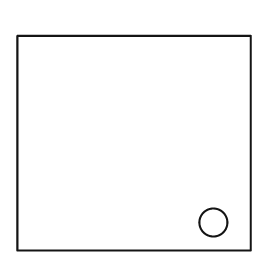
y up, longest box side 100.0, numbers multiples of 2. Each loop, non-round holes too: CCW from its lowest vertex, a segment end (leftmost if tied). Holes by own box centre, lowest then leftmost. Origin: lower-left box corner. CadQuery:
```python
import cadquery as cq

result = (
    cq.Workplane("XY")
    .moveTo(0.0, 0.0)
    .lineTo(100.0, 0.0)
    .lineTo(100.0, 92.0)
    .lineTo(0.0, 92.0)
    .close()
    .moveTo(84.0, 12.0)
    .circle(6.0)
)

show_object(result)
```